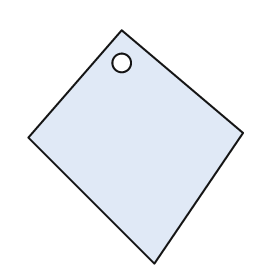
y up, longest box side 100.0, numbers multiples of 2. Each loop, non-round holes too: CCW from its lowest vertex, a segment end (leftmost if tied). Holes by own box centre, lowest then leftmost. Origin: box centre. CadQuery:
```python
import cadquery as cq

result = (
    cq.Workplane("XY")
    .moveTo(8.0, -50.0)
    .lineTo(46.0, 6.0)
    .lineTo(-6.0, 50.0)
    .lineTo(-46.0, 4.0)
    .close()
    .moveTo(-6.0, 36.0)
    .circle(4.0)
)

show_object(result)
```